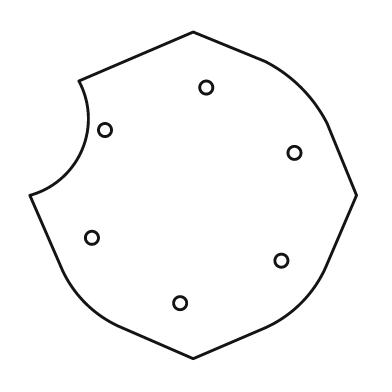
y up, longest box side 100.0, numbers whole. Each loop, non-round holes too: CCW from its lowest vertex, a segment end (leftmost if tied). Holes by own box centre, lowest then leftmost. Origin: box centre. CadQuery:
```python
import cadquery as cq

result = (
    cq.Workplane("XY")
    .moveTo(0.0, -50.0)
    .lineTo(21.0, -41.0)
    .threePointArc((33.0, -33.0), (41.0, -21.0))
    .lineTo(50.0, 0.0)
    .lineTo(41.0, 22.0)
    .threePointArc((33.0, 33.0), (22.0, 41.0))
    .lineTo(0.0, 50.0)
    .lineTo(-35.0, 35.0)
    .threePointArc((-34.0, 14.0), (-50.0, 0.0))
    .lineTo(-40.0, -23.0)
    .threePointArc((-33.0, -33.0), (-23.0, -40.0))
    .close()
    .moveTo(-4.0, -33.0)
    .circle(2.0)
    .moveTo(27.0, -20.0)
    .circle(2.0)
    .moveTo(-31.0, -13.0)
    .circle(2.0)
    .moveTo(31.0, 13.0)
    .circle(2.0)
    .moveTo(-27.0, 20.0)
    .circle(2.0)
    .moveTo(4.0, 33.0)
    .circle(2.0)
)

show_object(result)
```